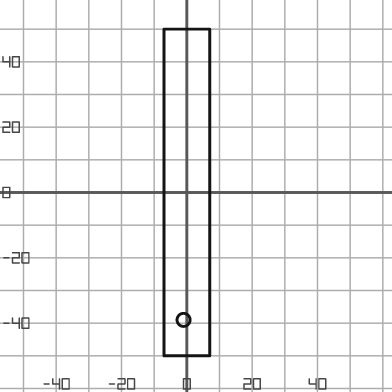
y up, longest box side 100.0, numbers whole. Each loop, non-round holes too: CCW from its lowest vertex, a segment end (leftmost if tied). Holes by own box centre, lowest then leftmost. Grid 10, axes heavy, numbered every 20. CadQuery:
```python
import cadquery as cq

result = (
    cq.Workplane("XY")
    .moveTo(-7.0, -50.0)
    .lineTo(7.0, -50.0)
    .lineTo(7.0, 50.0)
    .lineTo(-7.0, 50.0)
    .close()
    .moveTo(-1.0, -39.0)
    .circle(2.0)
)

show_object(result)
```